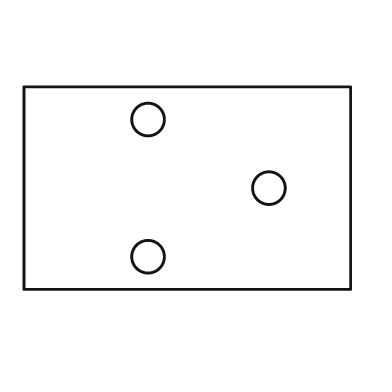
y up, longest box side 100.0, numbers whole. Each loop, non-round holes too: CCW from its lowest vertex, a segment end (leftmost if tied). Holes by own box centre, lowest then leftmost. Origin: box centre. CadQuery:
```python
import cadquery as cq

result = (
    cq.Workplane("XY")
    .moveTo(-50.0, -31.0)
    .lineTo(50.0, -31.0)
    .lineTo(50.0, 31.0)
    .lineTo(-50.0, 31.0)
    .close()
    .moveTo(-12.0, -21.0)
    .circle(5.0)
    .moveTo(25.0, 0.0)
    .circle(5.0)
    .moveTo(-12.0, 21.0)
    .circle(5.0)
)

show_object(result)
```